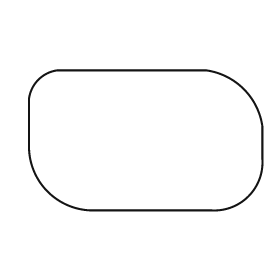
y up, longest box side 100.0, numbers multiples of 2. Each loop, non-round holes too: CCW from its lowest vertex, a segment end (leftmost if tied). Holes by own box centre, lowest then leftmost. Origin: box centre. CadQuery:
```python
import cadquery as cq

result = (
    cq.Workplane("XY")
    .moveTo(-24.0, -30.0)
    .lineTo(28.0, -30.0)
    .threePointArc((44.0, -24.0), (50.0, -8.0))
    .lineTo(50.0, 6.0)
    .threePointArc((42.0, 22.0), (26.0, 30.0))
    .lineTo(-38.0, 30.0)
    .threePointArc((-46.0, 26.0), (-50.0, 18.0))
    .lineTo(-50.0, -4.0)
    .threePointArc((-42.0, -22.0), (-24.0, -30.0))
    .close()
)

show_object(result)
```